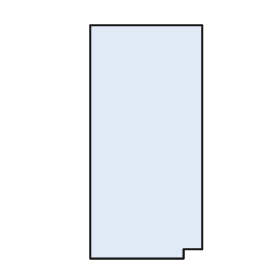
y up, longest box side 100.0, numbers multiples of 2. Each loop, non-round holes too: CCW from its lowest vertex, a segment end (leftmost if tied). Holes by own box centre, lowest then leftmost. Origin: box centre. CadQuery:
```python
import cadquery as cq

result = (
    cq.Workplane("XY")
    .moveTo(-24.0, -50.0)
    .lineTo(16.0, -50.0)
    .lineTo(16.0, -46.0)
    .lineTo(24.0, -46.0)
    .lineTo(24.0, 50.0)
    .lineTo(-24.0, 50.0)
    .close()
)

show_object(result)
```